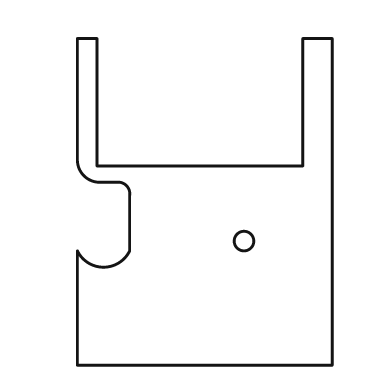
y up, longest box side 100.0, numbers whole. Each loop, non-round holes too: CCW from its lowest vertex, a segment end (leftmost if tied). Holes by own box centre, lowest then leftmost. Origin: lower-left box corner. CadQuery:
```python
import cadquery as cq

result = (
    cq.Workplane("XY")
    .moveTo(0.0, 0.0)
    .lineTo(78.0, 0.0)
    .lineTo(78.0, 100.0)
    .lineTo(69.0, 100.0)
    .lineTo(69.0, 61.0)
    .lineTo(6.0, 61.0)
    .lineTo(6.0, 100.0)
    .lineTo(0.0, 100.0)
    .lineTo(0.0, 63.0)
    .threePointArc((2.0, 58.0), (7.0, 56.0))
    .lineTo(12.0, 56.0)
    .threePointArc((15.0, 55.0), (16.0, 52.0))
    .lineTo(16.0, 35.0)
    .threePointArc((8.0, 30.0), (0.0, 35.0))
    .close()
    .moveTo(51.0, 38.0)
    .circle(3.0)
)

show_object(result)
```